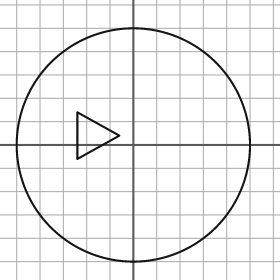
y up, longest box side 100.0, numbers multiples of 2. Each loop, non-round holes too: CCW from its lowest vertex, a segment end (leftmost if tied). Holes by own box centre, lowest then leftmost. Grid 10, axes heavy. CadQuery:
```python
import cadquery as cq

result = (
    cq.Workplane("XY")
    .moveTo(0.0, 0.0)
    .circle(50.0)
    .moveTo(-24.0, -6.0)
    .lineTo(-6.0, 4.0)
    .lineTo(-24.0, 14.0)
    .close()
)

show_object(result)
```